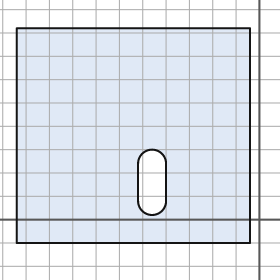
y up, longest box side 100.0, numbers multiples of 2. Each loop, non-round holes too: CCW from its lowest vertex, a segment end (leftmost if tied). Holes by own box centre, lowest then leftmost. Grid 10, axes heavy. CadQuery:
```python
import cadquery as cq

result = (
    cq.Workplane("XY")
    .moveTo(-104.0, -10.0)
    .lineTo(-4.0, -10.0)
    .lineTo(-4.0, 82.0)
    .lineTo(-104.0, 82.0)
    .close()
    .moveTo(-52.0, 8.0)
    .threePointArc((-46.0, 2.0), (-40.0, 8.0))
    .lineTo(-40.0, 24.0)
    .threePointArc((-46.0, 30.0), (-52.0, 24.0))
    .close()
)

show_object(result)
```